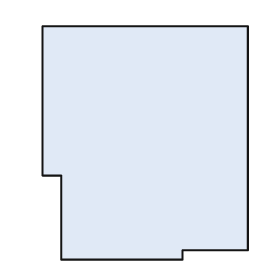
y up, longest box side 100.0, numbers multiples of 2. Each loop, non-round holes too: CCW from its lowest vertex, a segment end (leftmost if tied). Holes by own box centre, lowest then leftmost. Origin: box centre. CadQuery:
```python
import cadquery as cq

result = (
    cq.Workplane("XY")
    .moveTo(-36.0, -50.0)
    .lineTo(16.0, -50.0)
    .lineTo(16.0, -46.0)
    .lineTo(44.0, -46.0)
    .lineTo(44.0, 50.0)
    .lineTo(-44.0, 50.0)
    .lineTo(-44.0, -14.0)
    .lineTo(-36.0, -14.0)
    .close()
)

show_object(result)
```